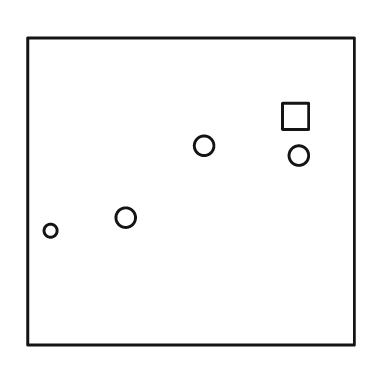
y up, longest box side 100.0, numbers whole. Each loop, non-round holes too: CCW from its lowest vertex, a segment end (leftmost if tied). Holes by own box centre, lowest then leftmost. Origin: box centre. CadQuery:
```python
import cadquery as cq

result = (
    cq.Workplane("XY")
    .moveTo(-50.0, -47.0)
    .lineTo(50.0, -47.0)
    .lineTo(50.0, 47.0)
    .lineTo(-50.0, 47.0)
    .close()
    .moveTo(-43.0, -12.0)
    .circle(2.0)
    .moveTo(-20.0, -8.0)
    .circle(3.0)
    .moveTo(33.0, 11.0)
    .circle(3.0)
    .moveTo(4.0, 14.0)
    .circle(3.0)
    .moveTo(28.0, 19.0)
    .lineTo(36.0, 19.0)
    .lineTo(36.0, 27.0)
    .lineTo(28.0, 27.0)
    .close()
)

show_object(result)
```